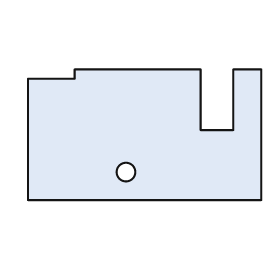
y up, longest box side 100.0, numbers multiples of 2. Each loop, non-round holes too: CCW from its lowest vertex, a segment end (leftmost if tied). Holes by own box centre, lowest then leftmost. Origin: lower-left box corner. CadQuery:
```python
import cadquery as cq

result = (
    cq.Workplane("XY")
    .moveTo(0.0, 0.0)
    .lineTo(100.0, 0.0)
    .lineTo(100.0, 56.0)
    .lineTo(88.0, 56.0)
    .lineTo(88.0, 30.0)
    .lineTo(74.0, 30.0)
    .lineTo(74.0, 56.0)
    .lineTo(20.0, 56.0)
    .lineTo(20.0, 52.0)
    .lineTo(0.0, 52.0)
    .close()
    .moveTo(42.0, 12.0)
    .circle(4.0)
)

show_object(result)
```